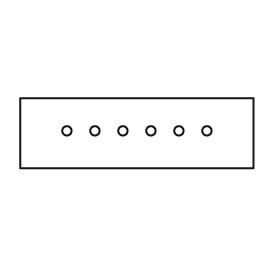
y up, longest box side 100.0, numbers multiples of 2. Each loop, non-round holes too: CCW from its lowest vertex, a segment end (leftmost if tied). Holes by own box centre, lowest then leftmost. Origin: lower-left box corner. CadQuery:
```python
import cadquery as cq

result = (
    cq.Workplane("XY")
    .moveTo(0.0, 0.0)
    .lineTo(100.0, 0.0)
    .lineTo(100.0, 30.0)
    .lineTo(0.0, 30.0)
    .close()
    .moveTo(20.0, 16.0)
    .circle(2.0)
    .moveTo(32.0, 16.0)
    .circle(2.0)
    .moveTo(44.0, 16.0)
    .circle(2.0)
    .moveTo(56.0, 16.0)
    .circle(2.0)
    .moveTo(68.0, 16.0)
    .circle(2.0)
    .moveTo(80.0, 16.0)
    .circle(2.0)
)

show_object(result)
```